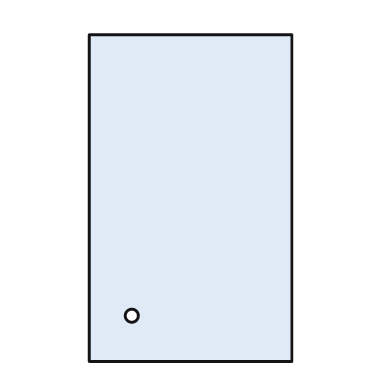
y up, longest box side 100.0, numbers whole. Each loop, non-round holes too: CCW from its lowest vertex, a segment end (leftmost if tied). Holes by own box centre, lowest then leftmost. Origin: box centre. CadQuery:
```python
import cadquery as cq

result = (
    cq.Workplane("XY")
    .moveTo(-31.0, -50.0)
    .lineTo(31.0, -50.0)
    .lineTo(31.0, 50.0)
    .lineTo(-31.0, 50.0)
    .close()
    .moveTo(-18.0, -36.0)
    .circle(2.0)
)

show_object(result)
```